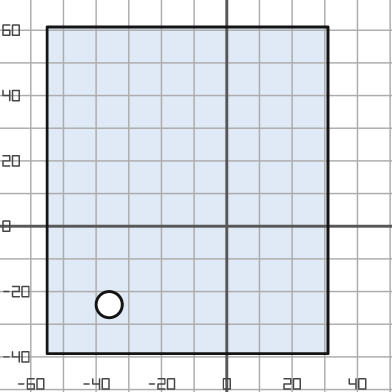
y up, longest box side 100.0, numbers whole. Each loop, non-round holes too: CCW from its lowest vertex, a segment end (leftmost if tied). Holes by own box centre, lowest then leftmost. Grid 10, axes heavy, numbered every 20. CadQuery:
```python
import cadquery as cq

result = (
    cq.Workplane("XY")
    .moveTo(-55.0, -39.0)
    .lineTo(31.0, -39.0)
    .lineTo(31.0, 61.0)
    .lineTo(-55.0, 61.0)
    .close()
    .moveTo(-36.0, -24.0)
    .circle(4.0)
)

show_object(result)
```